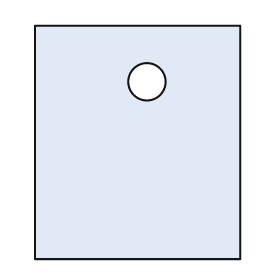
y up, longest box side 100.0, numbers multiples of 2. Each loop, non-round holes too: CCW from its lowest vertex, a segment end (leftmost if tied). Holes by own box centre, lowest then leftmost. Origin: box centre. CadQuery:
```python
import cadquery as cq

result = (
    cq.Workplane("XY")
    .moveTo(-44.0, -50.0)
    .lineTo(44.0, -50.0)
    .lineTo(44.0, 50.0)
    .lineTo(-44.0, 50.0)
    .close()
    .moveTo(4.0, 26.0)
    .circle(8.0)
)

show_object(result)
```